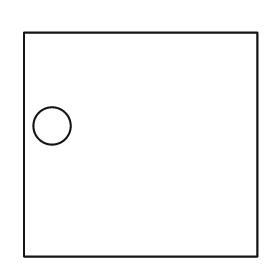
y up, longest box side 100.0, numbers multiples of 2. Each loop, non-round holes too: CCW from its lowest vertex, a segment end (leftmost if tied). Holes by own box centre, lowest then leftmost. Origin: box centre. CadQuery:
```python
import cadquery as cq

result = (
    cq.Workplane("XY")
    .moveTo(-50.0, -48.0)
    .lineTo(50.0, -48.0)
    .lineTo(50.0, 48.0)
    .lineTo(-50.0, 48.0)
    .close()
    .moveTo(-38.0, 8.0)
    .circle(8.0)
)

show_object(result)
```